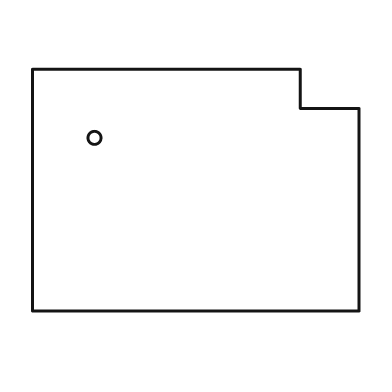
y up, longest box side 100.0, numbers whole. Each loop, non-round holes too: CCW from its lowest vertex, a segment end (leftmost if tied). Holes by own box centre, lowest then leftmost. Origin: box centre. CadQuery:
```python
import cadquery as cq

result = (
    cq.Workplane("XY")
    .moveTo(-50.0, -37.0)
    .lineTo(50.0, -37.0)
    .lineTo(50.0, 25.0)
    .lineTo(32.0, 25.0)
    .lineTo(32.0, 37.0)
    .lineTo(-50.0, 37.0)
    .close()
    .moveTo(-31.0, 16.0)
    .circle(2.0)
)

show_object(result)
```